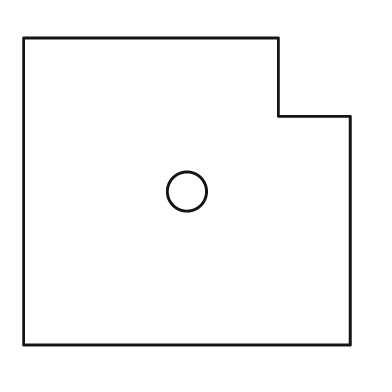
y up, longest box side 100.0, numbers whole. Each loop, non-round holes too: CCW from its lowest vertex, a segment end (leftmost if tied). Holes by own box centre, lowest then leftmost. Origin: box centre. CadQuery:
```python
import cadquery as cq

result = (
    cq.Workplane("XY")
    .moveTo(-50.0, -47.0)
    .lineTo(50.0, -47.0)
    .lineTo(50.0, 23.0)
    .lineTo(28.0, 23.0)
    .lineTo(28.0, 47.0)
    .lineTo(-50.0, 47.0)
    .close()
    .moveTo(0.0, 0.0)
    .circle(6.0)
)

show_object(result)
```